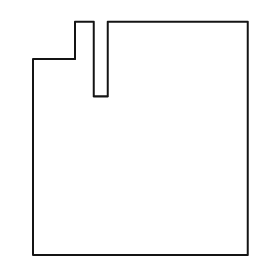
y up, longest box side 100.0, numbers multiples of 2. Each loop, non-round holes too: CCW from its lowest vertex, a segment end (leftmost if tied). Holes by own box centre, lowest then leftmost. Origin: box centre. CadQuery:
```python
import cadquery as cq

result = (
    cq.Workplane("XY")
    .moveTo(-46.0, -50.0)
    .lineTo(46.0, -50.0)
    .lineTo(46.0, 50.0)
    .lineTo(-14.0, 50.0)
    .lineTo(-14.0, 18.0)
    .lineTo(-20.0, 18.0)
    .lineTo(-20.0, 50.0)
    .lineTo(-28.0, 50.0)
    .lineTo(-28.0, 34.0)
    .lineTo(-46.0, 34.0)
    .close()
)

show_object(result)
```